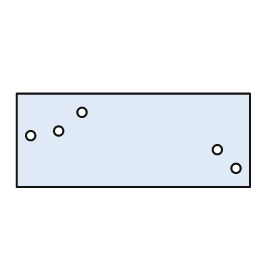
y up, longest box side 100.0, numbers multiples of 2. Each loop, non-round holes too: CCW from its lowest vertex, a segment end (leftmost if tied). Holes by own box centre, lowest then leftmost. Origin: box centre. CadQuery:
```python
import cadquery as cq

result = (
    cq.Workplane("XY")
    .moveTo(-50.0, -20.0)
    .lineTo(50.0, -20.0)
    .lineTo(50.0, 20.0)
    .lineTo(-50.0, 20.0)
    .close()
    .moveTo(44.0, -12.0)
    .circle(2.0)
    .moveTo(36.0, -4.0)
    .circle(2.0)
    .moveTo(-44.0, 2.0)
    .circle(2.0)
    .moveTo(-32.0, 4.0)
    .circle(2.0)
    .moveTo(-22.0, 12.0)
    .circle(2.0)
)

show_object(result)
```